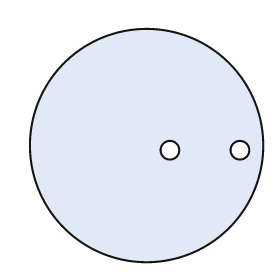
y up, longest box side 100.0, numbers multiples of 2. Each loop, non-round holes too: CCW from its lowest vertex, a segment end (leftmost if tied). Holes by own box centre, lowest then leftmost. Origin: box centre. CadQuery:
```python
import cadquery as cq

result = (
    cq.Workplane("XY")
    .moveTo(0.0, 0.0)
    .circle(50.0)
    .moveTo(10.0, -2.0)
    .circle(4.0)
    .moveTo(40.0, -2.0)
    .circle(4.0)
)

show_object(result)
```